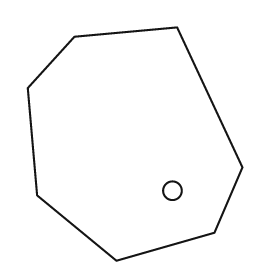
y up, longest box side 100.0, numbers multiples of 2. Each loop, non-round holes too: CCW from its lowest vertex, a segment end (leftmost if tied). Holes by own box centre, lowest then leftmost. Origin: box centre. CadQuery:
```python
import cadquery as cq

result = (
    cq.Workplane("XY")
    .moveTo(-8.0, -50.0)
    .lineTo(34.0, -38.0)
    .lineTo(46.0, -10.0)
    .lineTo(18.0, 50.0)
    .lineTo(-26.0, 46.0)
    .lineTo(-46.0, 24.0)
    .lineTo(-42.0, -22.0)
    .close()
    .moveTo(16.0, -20.0)
    .circle(4.0)
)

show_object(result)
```